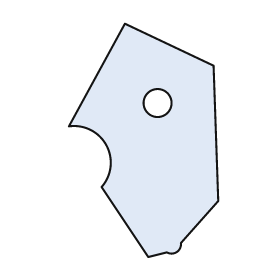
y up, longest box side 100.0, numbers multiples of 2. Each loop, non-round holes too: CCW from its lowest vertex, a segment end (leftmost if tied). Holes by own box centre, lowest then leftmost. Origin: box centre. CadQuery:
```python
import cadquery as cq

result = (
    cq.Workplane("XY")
    .moveTo(2.0, -50.0)
    .lineTo(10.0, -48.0)
    .threePointArc((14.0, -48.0), (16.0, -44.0))
    .lineTo(32.0, -26.0)
    .lineTo(30.0, 32.0)
    .lineTo(-8.0, 50.0)
    .lineTo(-32.0, 6.0)
    .threePointArc((-16.0, -2.0), (-18.0, -20.0))
    .close()
    .moveTo(6.0, 16.0)
    .circle(6.0)
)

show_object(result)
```